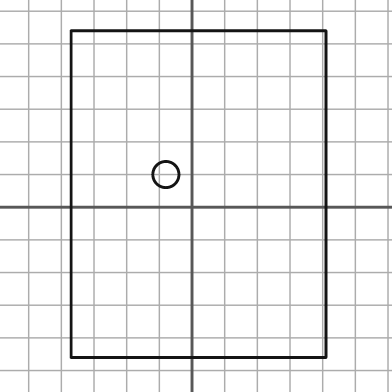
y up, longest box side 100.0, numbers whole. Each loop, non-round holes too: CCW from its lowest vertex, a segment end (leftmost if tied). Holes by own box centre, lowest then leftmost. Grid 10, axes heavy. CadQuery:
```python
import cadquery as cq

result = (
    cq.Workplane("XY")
    .moveTo(-37.0, -46.0)
    .lineTo(41.0, -46.0)
    .lineTo(41.0, 54.0)
    .lineTo(-37.0, 54.0)
    .close()
    .moveTo(-8.0, 10.0)
    .circle(4.0)
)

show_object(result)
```